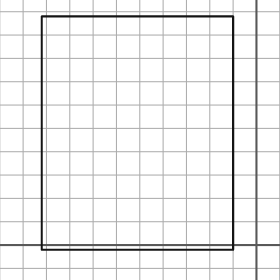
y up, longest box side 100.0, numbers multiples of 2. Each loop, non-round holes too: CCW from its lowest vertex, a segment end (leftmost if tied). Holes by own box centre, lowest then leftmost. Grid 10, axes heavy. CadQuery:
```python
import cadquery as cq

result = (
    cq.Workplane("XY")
    .moveTo(-92.0, -2.0)
    .lineTo(-10.0, -2.0)
    .lineTo(-10.0, 98.0)
    .lineTo(-92.0, 98.0)
    .close()
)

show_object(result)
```